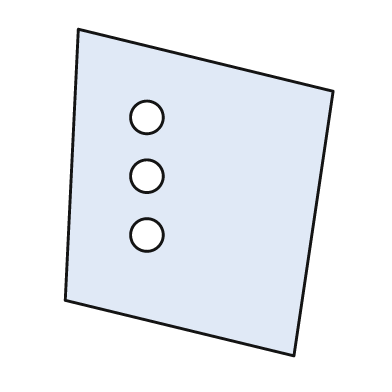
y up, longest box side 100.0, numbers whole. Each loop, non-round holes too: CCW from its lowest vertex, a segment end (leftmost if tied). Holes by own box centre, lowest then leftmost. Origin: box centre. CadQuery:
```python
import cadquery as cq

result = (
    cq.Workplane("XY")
    .moveTo(29.0, -50.0)
    .lineTo(41.0, 31.0)
    .lineTo(-37.0, 50.0)
    .lineTo(-41.0, -33.0)
    .close()
    .moveTo(-16.0, -13.0)
    .circle(5.0)
    .moveTo(-16.0, 5.0)
    .circle(5.0)
    .moveTo(-16.0, 23.0)
    .circle(5.0)
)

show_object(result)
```